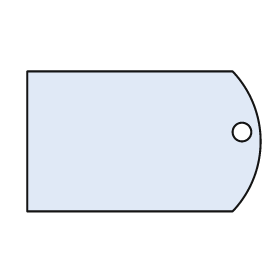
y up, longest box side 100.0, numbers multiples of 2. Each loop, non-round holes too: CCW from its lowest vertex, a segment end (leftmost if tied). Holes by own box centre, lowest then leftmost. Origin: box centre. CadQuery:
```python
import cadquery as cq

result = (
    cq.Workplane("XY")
    .moveTo(-50.0, -30.0)
    .lineTo(38.0, -30.0)
    .threePointArc((50.0, 0.0), (38.0, 30.0))
    .lineTo(-50.0, 30.0)
    .close()
    .moveTo(42.0, 4.0)
    .circle(4.0)
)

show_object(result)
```